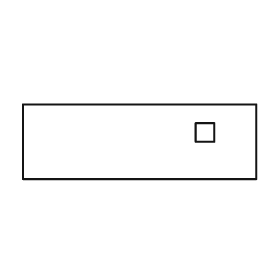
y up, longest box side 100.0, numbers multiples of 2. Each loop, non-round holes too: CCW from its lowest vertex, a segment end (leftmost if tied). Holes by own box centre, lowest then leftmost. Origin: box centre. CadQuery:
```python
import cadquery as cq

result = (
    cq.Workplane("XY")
    .moveTo(-50.0, -16.0)
    .lineTo(50.0, -16.0)
    .lineTo(50.0, 16.0)
    .lineTo(-50.0, 16.0)
    .close()
    .moveTo(24.0, 0.0)
    .lineTo(32.0, 0.0)
    .lineTo(32.0, 8.0)
    .lineTo(24.0, 8.0)
    .close()
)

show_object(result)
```